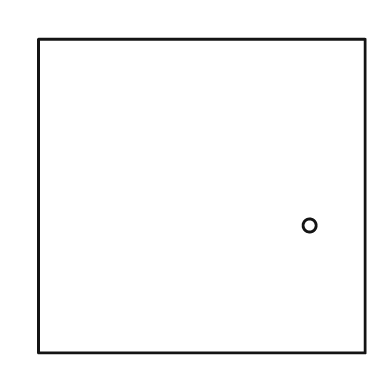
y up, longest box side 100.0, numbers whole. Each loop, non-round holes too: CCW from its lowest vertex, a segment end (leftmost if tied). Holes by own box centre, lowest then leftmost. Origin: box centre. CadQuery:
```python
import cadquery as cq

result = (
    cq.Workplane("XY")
    .moveTo(-50.0, -48.0)
    .lineTo(50.0, -48.0)
    .lineTo(50.0, 48.0)
    .lineTo(-50.0, 48.0)
    .close()
    .moveTo(33.0, -9.0)
    .circle(2.0)
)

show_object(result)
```